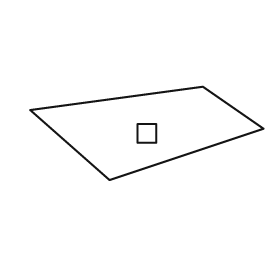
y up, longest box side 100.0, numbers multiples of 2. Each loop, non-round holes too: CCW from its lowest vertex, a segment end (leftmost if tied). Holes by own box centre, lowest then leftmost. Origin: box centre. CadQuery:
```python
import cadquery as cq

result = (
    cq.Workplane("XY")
    .moveTo(-16.0, -20.0)
    .lineTo(50.0, 2.0)
    .lineTo(24.0, 20.0)
    .lineTo(-50.0, 10.0)
    .close()
    .moveTo(-4.0, -4.0)
    .lineTo(4.0, -4.0)
    .lineTo(4.0, 4.0)
    .lineTo(-4.0, 4.0)
    .close()
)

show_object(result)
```